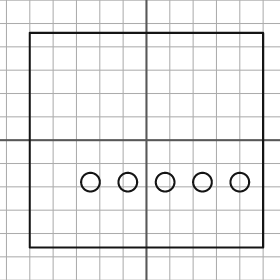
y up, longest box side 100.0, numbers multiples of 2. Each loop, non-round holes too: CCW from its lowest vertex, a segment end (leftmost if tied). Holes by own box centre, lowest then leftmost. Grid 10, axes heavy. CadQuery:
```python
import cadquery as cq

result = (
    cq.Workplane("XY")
    .moveTo(-50.0, -46.0)
    .lineTo(50.0, -46.0)
    .lineTo(50.0, 46.0)
    .lineTo(-50.0, 46.0)
    .close()
    .moveTo(-24.0, -18.0)
    .circle(4.0)
    .moveTo(-8.0, -18.0)
    .circle(4.0)
    .moveTo(8.0, -18.0)
    .circle(4.0)
    .moveTo(24.0, -18.0)
    .circle(4.0)
    .moveTo(40.0, -18.0)
    .circle(4.0)
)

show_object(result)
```